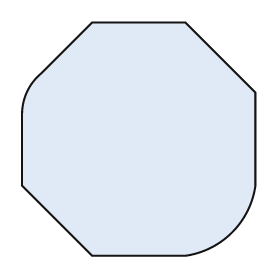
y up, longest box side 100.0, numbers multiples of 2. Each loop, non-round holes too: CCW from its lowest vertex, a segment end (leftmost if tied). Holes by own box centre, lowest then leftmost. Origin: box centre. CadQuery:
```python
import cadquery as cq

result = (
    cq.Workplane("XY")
    .moveTo(-20.0, -50.0)
    .lineTo(20.0, -50.0)
    .threePointArc((40.0, -40.0), (50.0, -20.0))
    .lineTo(50.0, 20.0)
    .lineTo(20.0, 50.0)
    .lineTo(-20.0, 50.0)
    .lineTo(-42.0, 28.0)
    .threePointArc((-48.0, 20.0), (-50.0, 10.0))
    .lineTo(-50.0, -20.0)
    .close()
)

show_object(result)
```